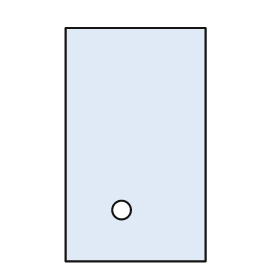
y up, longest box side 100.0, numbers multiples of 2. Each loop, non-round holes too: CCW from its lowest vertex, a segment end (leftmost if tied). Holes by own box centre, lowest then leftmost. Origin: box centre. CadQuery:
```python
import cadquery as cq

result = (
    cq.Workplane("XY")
    .moveTo(-30.0, -50.0)
    .lineTo(30.0, -50.0)
    .lineTo(30.0, 50.0)
    .lineTo(-30.0, 50.0)
    .close()
    .moveTo(-6.0, -28.0)
    .circle(4.0)
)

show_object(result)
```